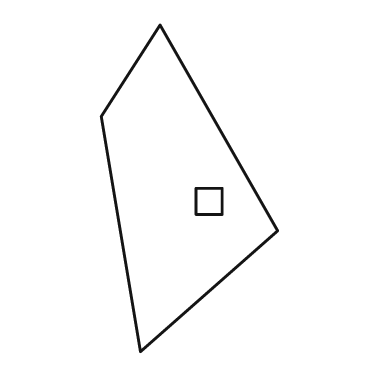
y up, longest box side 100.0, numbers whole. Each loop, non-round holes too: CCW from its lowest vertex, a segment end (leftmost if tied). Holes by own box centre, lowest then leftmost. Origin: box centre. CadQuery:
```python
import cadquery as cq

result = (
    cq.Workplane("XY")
    .moveTo(-15.0, -50.0)
    .lineTo(27.0, -13.0)
    .lineTo(-9.0, 50.0)
    .lineTo(-27.0, 22.0)
    .close()
    .moveTo(2.0, -8.0)
    .lineTo(10.0, -8.0)
    .lineTo(10.0, 0.0)
    .lineTo(2.0, 0.0)
    .close()
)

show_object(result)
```